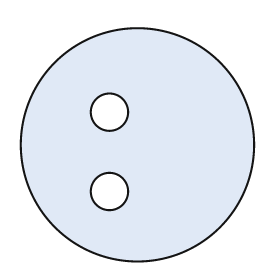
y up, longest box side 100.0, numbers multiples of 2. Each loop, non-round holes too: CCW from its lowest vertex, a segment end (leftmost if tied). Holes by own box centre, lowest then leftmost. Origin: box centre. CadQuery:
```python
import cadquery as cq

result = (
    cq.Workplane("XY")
    .moveTo(0.0, 0.0)
    .circle(50.0)
    .moveTo(-12.0, -20.0)
    .circle(8.0)
    .moveTo(-12.0, 14.0)
    .circle(8.0)
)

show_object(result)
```